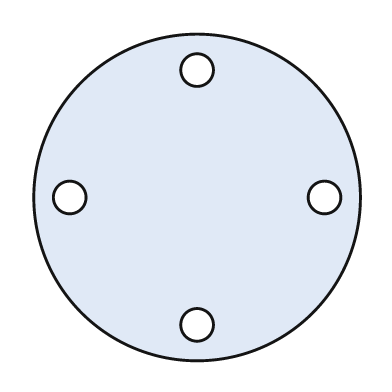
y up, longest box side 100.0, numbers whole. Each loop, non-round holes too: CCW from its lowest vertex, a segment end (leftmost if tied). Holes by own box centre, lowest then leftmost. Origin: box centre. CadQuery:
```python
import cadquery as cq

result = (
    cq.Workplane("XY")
    .moveTo(0.0, 0.0)
    .circle(50.0)
    .moveTo(0.0, -39.0)
    .circle(5.0)
    .moveTo(-39.0, 0.0)
    .circle(5.0)
    .moveTo(39.0, 0.0)
    .circle(5.0)
    .moveTo(0.0, 39.0)
    .circle(5.0)
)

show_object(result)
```